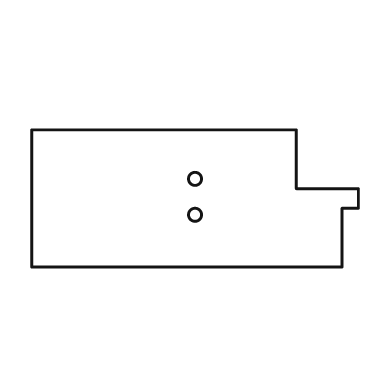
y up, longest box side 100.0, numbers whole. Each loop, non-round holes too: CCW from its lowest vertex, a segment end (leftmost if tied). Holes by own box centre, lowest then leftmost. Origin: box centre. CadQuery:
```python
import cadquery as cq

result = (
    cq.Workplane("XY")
    .moveTo(-50.0, -21.0)
    .lineTo(45.0, -21.0)
    .lineTo(45.0, -3.0)
    .lineTo(50.0, -3.0)
    .lineTo(50.0, 3.0)
    .lineTo(31.0, 3.0)
    .lineTo(31.0, 21.0)
    .lineTo(-50.0, 21.0)
    .close()
    .moveTo(0.0, -5.0)
    .circle(2.0)
    .moveTo(0.0, 6.0)
    .circle(2.0)
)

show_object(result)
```